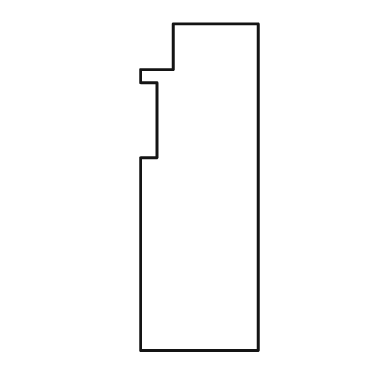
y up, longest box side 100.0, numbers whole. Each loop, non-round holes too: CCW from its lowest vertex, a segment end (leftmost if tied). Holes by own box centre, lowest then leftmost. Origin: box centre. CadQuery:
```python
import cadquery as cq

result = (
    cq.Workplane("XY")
    .moveTo(-18.0, -50.0)
    .lineTo(18.0, -50.0)
    .lineTo(18.0, 50.0)
    .lineTo(-8.0, 50.0)
    .lineTo(-8.0, 36.0)
    .lineTo(-18.0, 36.0)
    .lineTo(-18.0, 32.0)
    .lineTo(-13.0, 32.0)
    .lineTo(-13.0, 9.0)
    .lineTo(-18.0, 9.0)
    .close()
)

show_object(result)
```